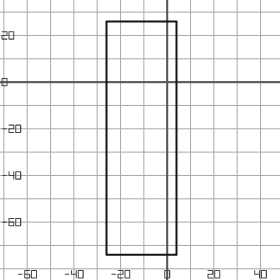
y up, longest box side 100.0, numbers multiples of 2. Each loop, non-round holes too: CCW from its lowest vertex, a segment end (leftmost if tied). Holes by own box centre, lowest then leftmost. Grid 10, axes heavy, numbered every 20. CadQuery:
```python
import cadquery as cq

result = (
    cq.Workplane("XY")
    .moveTo(-26.0, -74.0)
    .lineTo(4.0, -74.0)
    .lineTo(4.0, 26.0)
    .lineTo(-26.0, 26.0)
    .close()
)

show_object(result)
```